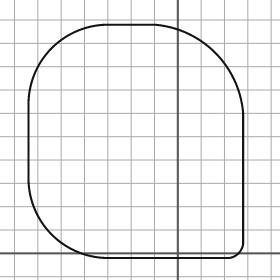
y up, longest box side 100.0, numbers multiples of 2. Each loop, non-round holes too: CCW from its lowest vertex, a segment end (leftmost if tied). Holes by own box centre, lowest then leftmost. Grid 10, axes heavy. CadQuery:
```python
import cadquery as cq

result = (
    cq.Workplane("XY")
    .moveTo(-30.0, -2.0)
    .lineTo(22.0, -2.0)
    .threePointArc((26.0, 0.0), (28.0, 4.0))
    .lineTo(28.0, 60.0)
    .threePointArc((16.0, 86.0), (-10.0, 98.0))
    .lineTo(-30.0, 98.0)
    .threePointArc((-54.0, 88.0), (-64.0, 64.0))
    .lineTo(-64.0, 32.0)
    .threePointArc((-54.0, 8.0), (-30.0, -2.0))
    .close()
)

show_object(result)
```